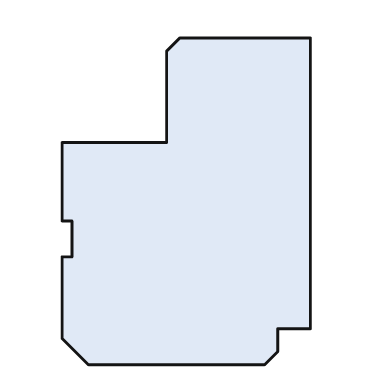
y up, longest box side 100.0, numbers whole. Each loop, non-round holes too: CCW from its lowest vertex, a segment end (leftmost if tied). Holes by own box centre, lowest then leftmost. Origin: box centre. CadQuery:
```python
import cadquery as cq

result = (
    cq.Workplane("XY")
    .moveTo(-30.0, -50.0)
    .lineTo(24.0, -50.0)
    .lineTo(28.0, -46.0)
    .lineTo(28.0, -39.0)
    .lineTo(38.0, -39.0)
    .lineTo(38.0, 50.0)
    .lineTo(-2.0, 50.0)
    .lineTo(-6.0, 46.0)
    .lineTo(-6.0, 18.0)
    .lineTo(-38.0, 18.0)
    .lineTo(-38.0, -6.0)
    .lineTo(-35.0, -6.0)
    .lineTo(-35.0, -17.0)
    .lineTo(-38.0, -17.0)
    .lineTo(-38.0, -42.0)
    .close()
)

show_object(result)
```